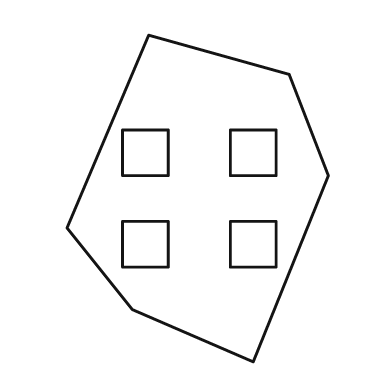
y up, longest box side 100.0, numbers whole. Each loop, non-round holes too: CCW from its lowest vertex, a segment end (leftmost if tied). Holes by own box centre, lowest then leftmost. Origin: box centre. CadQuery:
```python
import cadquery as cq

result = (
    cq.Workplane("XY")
    .moveTo(17.0, -50.0)
    .lineTo(40.0, 7.0)
    .lineTo(28.0, 38.0)
    .lineTo(-15.0, 50.0)
    .lineTo(-40.0, -9.0)
    .lineTo(-20.0, -34.0)
    .close()
    .moveTo(-23.0, -21.0)
    .lineTo(-9.0, -21.0)
    .lineTo(-9.0, -7.0)
    .lineTo(-23.0, -7.0)
    .close()
    .moveTo(10.0, -21.0)
    .lineTo(24.0, -21.0)
    .lineTo(24.0, -7.0)
    .lineTo(10.0, -7.0)
    .close()
    .moveTo(-23.0, 7.0)
    .lineTo(-9.0, 7.0)
    .lineTo(-9.0, 21.0)
    .lineTo(-23.0, 21.0)
    .close()
    .moveTo(10.0, 7.0)
    .lineTo(24.0, 7.0)
    .lineTo(24.0, 21.0)
    .lineTo(10.0, 21.0)
    .close()
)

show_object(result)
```